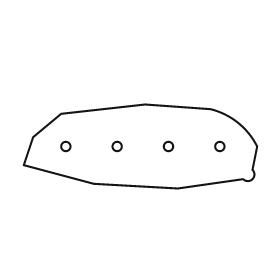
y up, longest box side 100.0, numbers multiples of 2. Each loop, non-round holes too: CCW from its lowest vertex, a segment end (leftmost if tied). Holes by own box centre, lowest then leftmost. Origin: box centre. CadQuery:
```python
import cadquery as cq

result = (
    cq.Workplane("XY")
    .moveTo(16.0, -18.0)
    .lineTo(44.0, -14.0)
    .threePointArc((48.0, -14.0), (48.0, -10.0))
    .lineTo(50.0, 0.0)
    .threePointArc((42.0, 10.0), (30.0, 16.0))
    .lineTo(2.0, 18.0)
    .lineTo(-34.0, 14.0)
    .lineTo(-46.0, 4.0)
    .lineTo(-50.0, -8.0)
    .lineTo(-20.0, -16.0)
    .close()
    .moveTo(-32.0, 0.0)
    .circle(2.0)
    .moveTo(-10.0, 0.0)
    .circle(2.0)
    .moveTo(12.0, 0.0)
    .circle(2.0)
    .moveTo(34.0, 0.0)
    .circle(2.0)
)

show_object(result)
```